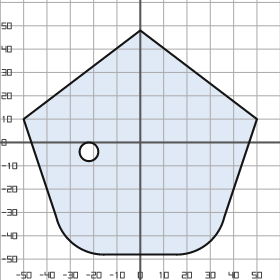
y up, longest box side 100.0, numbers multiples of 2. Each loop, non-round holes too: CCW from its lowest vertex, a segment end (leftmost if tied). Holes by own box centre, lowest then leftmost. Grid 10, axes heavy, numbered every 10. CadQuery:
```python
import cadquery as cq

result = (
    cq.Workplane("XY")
    .moveTo(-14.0, -48.0)
    .lineTo(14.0, -48.0)
    .threePointArc((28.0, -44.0), (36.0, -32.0))
    .lineTo(50.0, 10.0)
    .lineTo(0.0, 48.0)
    .lineTo(-50.0, 10.0)
    .lineTo(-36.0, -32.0)
    .threePointArc((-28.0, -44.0), (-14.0, -48.0))
    .close()
    .moveTo(-22.0, -4.0)
    .circle(4.0)
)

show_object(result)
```